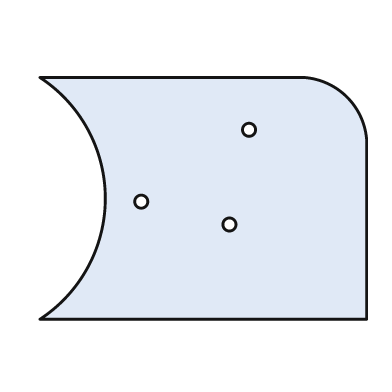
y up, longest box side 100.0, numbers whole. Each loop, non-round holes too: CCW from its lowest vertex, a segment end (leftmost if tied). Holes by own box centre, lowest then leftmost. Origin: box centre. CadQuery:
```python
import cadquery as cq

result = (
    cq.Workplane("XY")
    .moveTo(-50.0, -37.0)
    .lineTo(50.0, -37.0)
    .lineTo(50.0, 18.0)
    .threePointArc((44.0, 31.0), (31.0, 37.0))
    .lineTo(-50.0, 37.0)
    .threePointArc((-30.0, 0.0), (-50.0, -37.0))
    .close()
    .moveTo(8.0, -8.0)
    .circle(2.0)
    .moveTo(-19.0, -1.0)
    .circle(2.0)
    .moveTo(14.0, 21.0)
    .circle(2.0)
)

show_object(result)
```